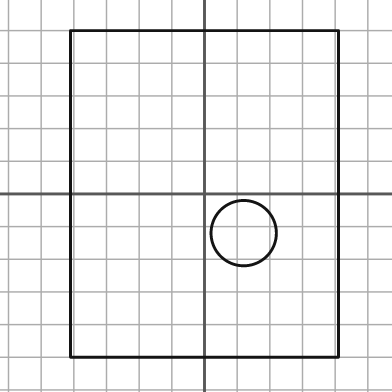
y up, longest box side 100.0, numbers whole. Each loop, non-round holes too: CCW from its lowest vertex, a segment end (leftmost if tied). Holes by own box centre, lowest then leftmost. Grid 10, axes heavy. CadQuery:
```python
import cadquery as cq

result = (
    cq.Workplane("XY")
    .moveTo(-41.0, -50.0)
    .lineTo(41.0, -50.0)
    .lineTo(41.0, 50.0)
    .lineTo(-41.0, 50.0)
    .close()
    .moveTo(12.0, -12.0)
    .circle(10.0)
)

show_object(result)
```